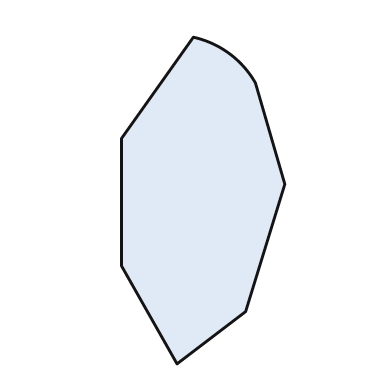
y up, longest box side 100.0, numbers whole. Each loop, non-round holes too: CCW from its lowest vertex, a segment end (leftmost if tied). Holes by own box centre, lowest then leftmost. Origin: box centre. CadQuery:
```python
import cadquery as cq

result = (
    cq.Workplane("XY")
    .moveTo(-8.0, -50.0)
    .lineTo(13.0, -34.0)
    .lineTo(25.0, 5.0)
    .lineTo(16.0, 36.0)
    .threePointArc((8.0, 45.0), (-3.0, 50.0))
    .lineTo(-25.0, 19.0)
    .lineTo(-25.0, -20.0)
    .close()
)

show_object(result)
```